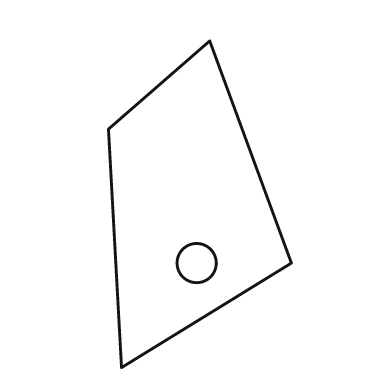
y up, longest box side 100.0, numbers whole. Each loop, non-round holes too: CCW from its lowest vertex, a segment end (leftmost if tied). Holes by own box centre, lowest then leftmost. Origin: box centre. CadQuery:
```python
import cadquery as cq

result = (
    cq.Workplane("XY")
    .moveTo(-24.0, -50.0)
    .lineTo(28.0, -18.0)
    .lineTo(3.0, 50.0)
    .lineTo(-28.0, 23.0)
    .close()
    .moveTo(-1.0, -18.0)
    .circle(6.0)
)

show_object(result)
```